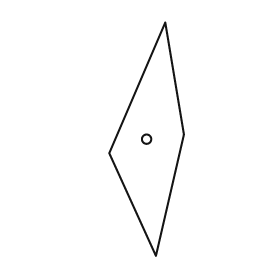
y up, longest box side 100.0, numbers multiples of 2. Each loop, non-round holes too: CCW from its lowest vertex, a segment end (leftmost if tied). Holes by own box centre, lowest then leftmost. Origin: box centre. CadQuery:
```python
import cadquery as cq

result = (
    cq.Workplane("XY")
    .moveTo(4.0, -50.0)
    .lineTo(16.0, 2.0)
    .lineTo(8.0, 50.0)
    .lineTo(-16.0, -6.0)
    .close()
    .moveTo(0.0, 0.0)
    .circle(2.0)
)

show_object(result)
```